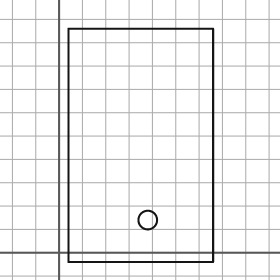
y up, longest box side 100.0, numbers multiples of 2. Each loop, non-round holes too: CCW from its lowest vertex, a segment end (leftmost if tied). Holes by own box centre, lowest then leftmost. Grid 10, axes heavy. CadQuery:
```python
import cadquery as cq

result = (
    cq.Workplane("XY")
    .moveTo(4.0, -4.0)
    .lineTo(66.0, -4.0)
    .lineTo(66.0, 96.0)
    .lineTo(4.0, 96.0)
    .close()
    .moveTo(38.0, 14.0)
    .circle(4.0)
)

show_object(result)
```